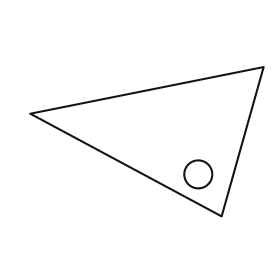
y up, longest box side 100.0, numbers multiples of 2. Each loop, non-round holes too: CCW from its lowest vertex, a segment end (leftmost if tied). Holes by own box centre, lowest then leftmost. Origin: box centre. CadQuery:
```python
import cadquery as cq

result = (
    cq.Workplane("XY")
    .moveTo(32.0, -32.0)
    .lineTo(50.0, 32.0)
    .lineTo(-50.0, 12.0)
    .close()
    .moveTo(22.0, -14.0)
    .circle(6.0)
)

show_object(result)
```